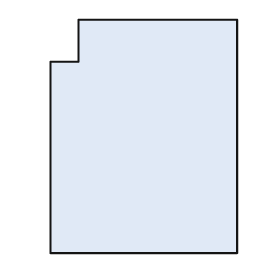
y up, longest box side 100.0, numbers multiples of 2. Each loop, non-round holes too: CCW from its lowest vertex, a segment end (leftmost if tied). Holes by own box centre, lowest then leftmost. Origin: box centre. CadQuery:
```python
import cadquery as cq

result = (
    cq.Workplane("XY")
    .moveTo(-40.0, -50.0)
    .lineTo(40.0, -50.0)
    .lineTo(40.0, 50.0)
    .lineTo(-28.0, 50.0)
    .lineTo(-28.0, 32.0)
    .lineTo(-40.0, 32.0)
    .close()
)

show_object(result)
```